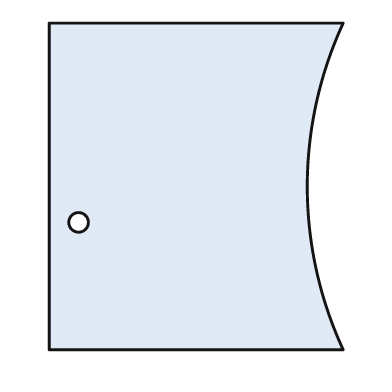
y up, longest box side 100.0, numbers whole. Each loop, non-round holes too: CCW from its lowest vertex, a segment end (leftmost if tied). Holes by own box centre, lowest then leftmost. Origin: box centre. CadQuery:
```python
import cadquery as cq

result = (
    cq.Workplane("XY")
    .moveTo(-45.0, -50.0)
    .lineTo(45.0, -50.0)
    .threePointArc((34.0, 0.0), (45.0, 50.0))
    .lineTo(-45.0, 50.0)
    .close()
    .moveTo(-36.0, -11.0)
    .circle(3.0)
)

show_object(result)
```